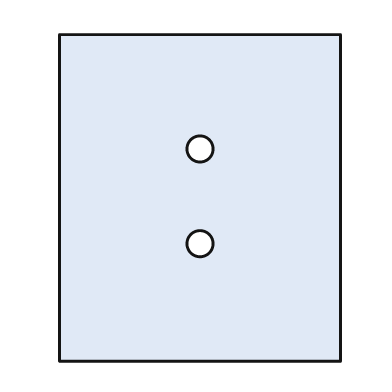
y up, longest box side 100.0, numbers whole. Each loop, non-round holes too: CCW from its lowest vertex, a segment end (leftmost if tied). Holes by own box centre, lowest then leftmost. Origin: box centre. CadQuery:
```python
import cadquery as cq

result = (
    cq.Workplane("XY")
    .moveTo(-43.0, -50.0)
    .lineTo(43.0, -50.0)
    .lineTo(43.0, 50.0)
    .lineTo(-43.0, 50.0)
    .close()
    .moveTo(0.0, -14.0)
    .circle(4.0)
    .moveTo(0.0, 15.0)
    .circle(4.0)
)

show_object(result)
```